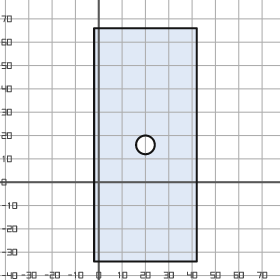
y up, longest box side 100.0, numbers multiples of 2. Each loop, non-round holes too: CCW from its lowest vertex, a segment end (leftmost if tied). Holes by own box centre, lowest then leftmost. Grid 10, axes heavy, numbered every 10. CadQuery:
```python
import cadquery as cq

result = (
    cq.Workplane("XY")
    .moveTo(-2.0, -34.0)
    .lineTo(42.0, -34.0)
    .lineTo(42.0, 66.0)
    .lineTo(-2.0, 66.0)
    .close()
    .moveTo(20.0, 16.0)
    .circle(4.0)
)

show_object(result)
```